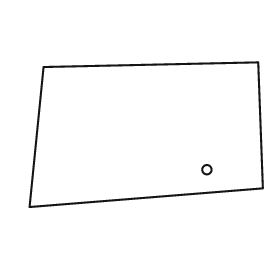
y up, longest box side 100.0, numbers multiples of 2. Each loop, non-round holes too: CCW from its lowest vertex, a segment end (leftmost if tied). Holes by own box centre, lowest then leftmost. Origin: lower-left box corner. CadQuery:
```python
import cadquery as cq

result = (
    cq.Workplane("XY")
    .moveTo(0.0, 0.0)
    .lineTo(100.0, 8.0)
    .lineTo(98.0, 62.0)
    .lineTo(6.0, 60.0)
    .close()
    .moveTo(76.0, 16.0)
    .circle(2.0)
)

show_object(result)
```